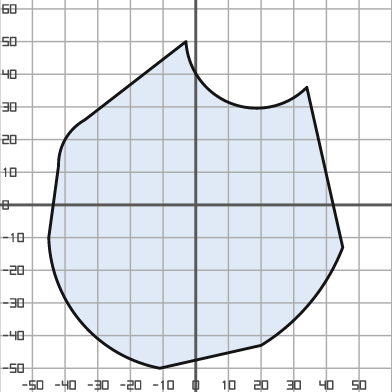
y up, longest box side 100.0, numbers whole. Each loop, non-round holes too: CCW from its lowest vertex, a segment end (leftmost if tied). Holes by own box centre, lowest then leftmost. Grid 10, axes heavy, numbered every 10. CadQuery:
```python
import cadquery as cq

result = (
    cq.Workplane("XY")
    .moveTo(-11.0, -50.0)
    .lineTo(20.0, -43.0)
    .threePointArc((35.0, -30.0), (45.0, -13.0))
    .lineTo(34.0, 36.0)
    .threePointArc((11.0, 31.0), (-3.0, 50.0))
    .lineTo(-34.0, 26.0)
    .threePointArc((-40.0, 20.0), (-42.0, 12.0))
    .lineTo(-45.0, -10.0)
    .threePointArc((-35.0, -36.0), (-11.0, -50.0))
    .close()
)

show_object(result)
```